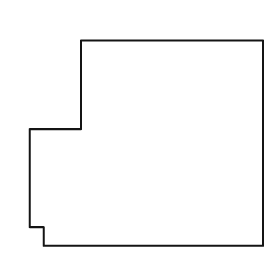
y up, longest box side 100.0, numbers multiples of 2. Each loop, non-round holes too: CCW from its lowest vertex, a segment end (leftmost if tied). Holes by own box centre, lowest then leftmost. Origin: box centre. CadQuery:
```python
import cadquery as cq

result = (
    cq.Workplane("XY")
    .moveTo(-44.0, -44.0)
    .lineTo(50.0, -44.0)
    .lineTo(50.0, 44.0)
    .lineTo(-28.0, 44.0)
    .lineTo(-28.0, 6.0)
    .lineTo(-50.0, 6.0)
    .lineTo(-50.0, -36.0)
    .lineTo(-44.0, -36.0)
    .close()
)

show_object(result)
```